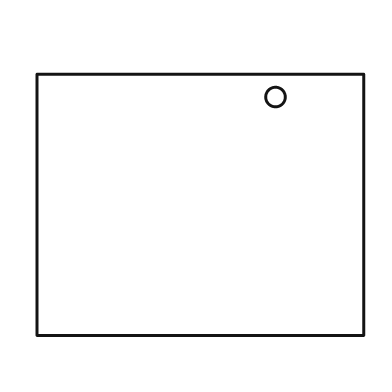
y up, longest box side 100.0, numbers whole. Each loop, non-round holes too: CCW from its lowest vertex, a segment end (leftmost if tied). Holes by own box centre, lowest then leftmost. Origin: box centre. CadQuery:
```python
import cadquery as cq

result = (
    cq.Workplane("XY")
    .moveTo(-50.0, -40.0)
    .lineTo(50.0, -40.0)
    .lineTo(50.0, 40.0)
    .lineTo(-50.0, 40.0)
    .close()
    .moveTo(23.0, 33.0)
    .circle(3.0)
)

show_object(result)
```